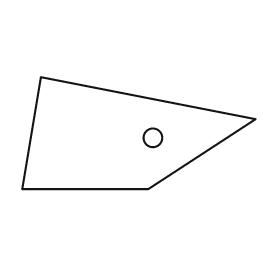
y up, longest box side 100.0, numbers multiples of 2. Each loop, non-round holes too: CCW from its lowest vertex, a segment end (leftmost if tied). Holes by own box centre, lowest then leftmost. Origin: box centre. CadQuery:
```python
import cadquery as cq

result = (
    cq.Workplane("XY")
    .moveTo(-50.0, -24.0)
    .lineTo(4.0, -24.0)
    .lineTo(50.0, 6.0)
    .lineTo(-42.0, 24.0)
    .close()
    .moveTo(6.0, -2.0)
    .circle(4.0)
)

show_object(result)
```